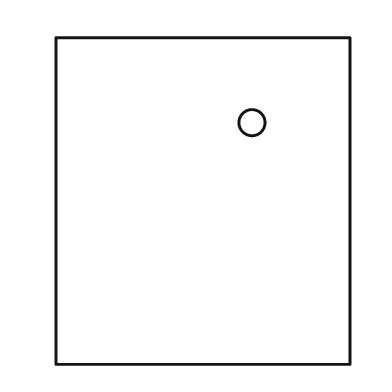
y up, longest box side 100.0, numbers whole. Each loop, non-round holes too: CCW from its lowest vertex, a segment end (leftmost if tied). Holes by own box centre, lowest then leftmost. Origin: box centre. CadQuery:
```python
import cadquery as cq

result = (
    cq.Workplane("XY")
    .moveTo(-45.0, -50.0)
    .lineTo(45.0, -50.0)
    .lineTo(45.0, 50.0)
    .lineTo(-45.0, 50.0)
    .close()
    .moveTo(15.0, 24.0)
    .circle(4.0)
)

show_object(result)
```